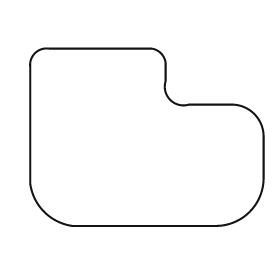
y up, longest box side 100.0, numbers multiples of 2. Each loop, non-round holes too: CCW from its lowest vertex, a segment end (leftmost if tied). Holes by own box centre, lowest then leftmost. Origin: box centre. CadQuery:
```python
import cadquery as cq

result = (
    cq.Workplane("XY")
    .moveTo(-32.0, -38.0)
    .lineTo(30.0, -38.0)
    .threePointArc((44.0, -32.0), (50.0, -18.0))
    .lineTo(50.0, 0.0)
    .threePointArc((46.0, 10.0), (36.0, 14.0))
    .lineTo(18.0, 14.0)
    .threePointArc((10.0, 16.0), (8.0, 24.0))
    .lineTo(8.0, 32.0)
    .threePointArc((6.0, 36.0), (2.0, 38.0))
    .lineTo(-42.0, 38.0)
    .threePointArc((-48.0, 36.0), (-50.0, 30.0))
    .lineTo(-50.0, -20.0)
    .threePointArc((-44.0, -32.0), (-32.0, -38.0))
    .close()
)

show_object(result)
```